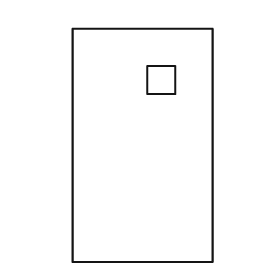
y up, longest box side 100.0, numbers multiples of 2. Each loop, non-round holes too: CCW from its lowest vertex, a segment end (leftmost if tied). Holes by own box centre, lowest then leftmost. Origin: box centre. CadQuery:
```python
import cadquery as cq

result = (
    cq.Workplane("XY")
    .moveTo(-30.0, -50.0)
    .lineTo(30.0, -50.0)
    .lineTo(30.0, 50.0)
    .lineTo(-30.0, 50.0)
    .close()
    .moveTo(2.0, 22.0)
    .lineTo(14.0, 22.0)
    .lineTo(14.0, 34.0)
    .lineTo(2.0, 34.0)
    .close()
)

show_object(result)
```